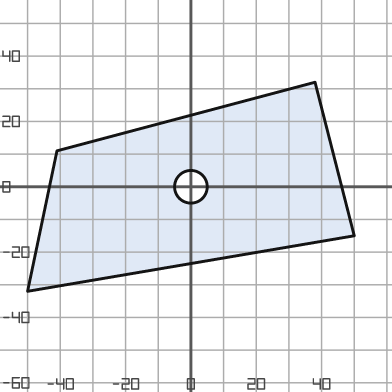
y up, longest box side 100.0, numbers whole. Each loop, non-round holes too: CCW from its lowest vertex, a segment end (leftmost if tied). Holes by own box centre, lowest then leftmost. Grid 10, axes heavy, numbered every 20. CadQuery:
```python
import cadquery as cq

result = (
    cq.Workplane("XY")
    .moveTo(-50.0, -32.0)
    .lineTo(50.0, -15.0)
    .lineTo(38.0, 32.0)
    .lineTo(-41.0, 11.0)
    .close()
    .moveTo(0.0, 0.0)
    .circle(5.0)
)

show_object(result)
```